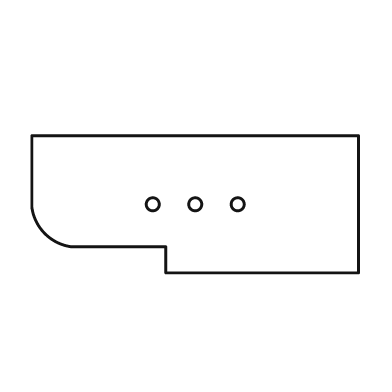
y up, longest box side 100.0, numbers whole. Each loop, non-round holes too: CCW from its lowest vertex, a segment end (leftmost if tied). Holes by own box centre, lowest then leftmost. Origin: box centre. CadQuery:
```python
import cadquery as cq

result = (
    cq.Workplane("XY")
    .moveTo(-9.0, -21.0)
    .lineTo(50.0, -21.0)
    .lineTo(50.0, 21.0)
    .lineTo(-50.0, 21.0)
    .lineTo(-50.0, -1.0)
    .threePointArc((-46.0, -9.0), (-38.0, -13.0))
    .lineTo(-9.0, -13.0)
    .close()
    .moveTo(-13.0, 0.0)
    .circle(2.0)
    .moveTo(0.0, 0.0)
    .circle(2.0)
    .moveTo(13.0, 0.0)
    .circle(2.0)
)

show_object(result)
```